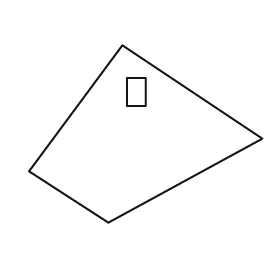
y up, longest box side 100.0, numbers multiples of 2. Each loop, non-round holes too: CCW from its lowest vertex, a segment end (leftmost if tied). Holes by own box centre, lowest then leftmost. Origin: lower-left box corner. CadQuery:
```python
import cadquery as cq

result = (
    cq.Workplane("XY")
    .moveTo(34.0, 0.0)
    .lineTo(100.0, 36.0)
    .lineTo(40.0, 76.0)
    .lineTo(0.0, 22.0)
    .close()
    .moveTo(42.0, 50.0)
    .lineTo(50.0, 50.0)
    .lineTo(50.0, 62.0)
    .lineTo(42.0, 62.0)
    .close()
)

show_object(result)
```